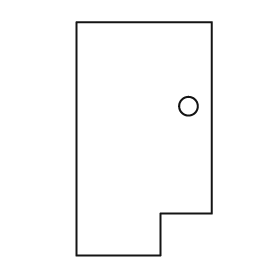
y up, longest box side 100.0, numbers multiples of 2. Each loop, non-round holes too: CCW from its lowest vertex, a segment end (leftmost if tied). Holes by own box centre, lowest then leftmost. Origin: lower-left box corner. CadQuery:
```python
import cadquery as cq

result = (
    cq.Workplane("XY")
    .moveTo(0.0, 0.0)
    .lineTo(36.0, 0.0)
    .lineTo(36.0, 18.0)
    .lineTo(58.0, 18.0)
    .lineTo(58.0, 100.0)
    .lineTo(0.0, 100.0)
    .close()
    .moveTo(48.0, 64.0)
    .circle(4.0)
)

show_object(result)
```